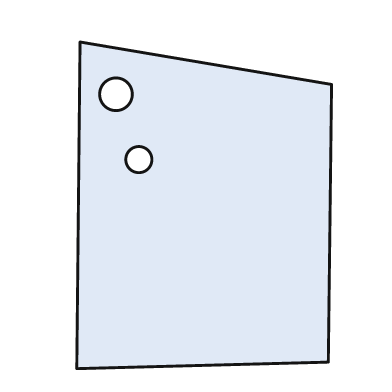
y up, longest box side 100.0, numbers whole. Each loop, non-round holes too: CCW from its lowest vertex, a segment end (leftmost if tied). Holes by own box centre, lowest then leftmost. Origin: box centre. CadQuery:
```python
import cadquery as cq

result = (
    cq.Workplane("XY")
    .moveTo(-39.0, -50.0)
    .lineTo(38.0, -48.0)
    .lineTo(39.0, 37.0)
    .lineTo(-38.0, 50.0)
    .close()
    .moveTo(-20.0, 14.0)
    .circle(4.0)
    .moveTo(-27.0, 34.0)
    .circle(5.0)
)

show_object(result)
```